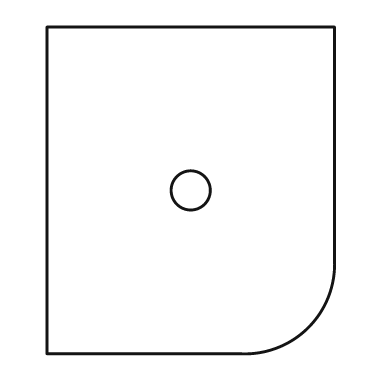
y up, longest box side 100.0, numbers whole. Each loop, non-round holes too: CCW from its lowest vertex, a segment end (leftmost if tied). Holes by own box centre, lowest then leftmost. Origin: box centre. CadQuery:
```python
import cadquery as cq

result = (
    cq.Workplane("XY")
    .moveTo(-44.0, -50.0)
    .lineTo(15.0, -50.0)
    .threePointArc((36.0, -42.0), (44.0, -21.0))
    .lineTo(44.0, 50.0)
    .lineTo(-44.0, 50.0)
    .close()
    .moveTo(0.0, 0.0)
    .circle(6.0)
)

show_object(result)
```